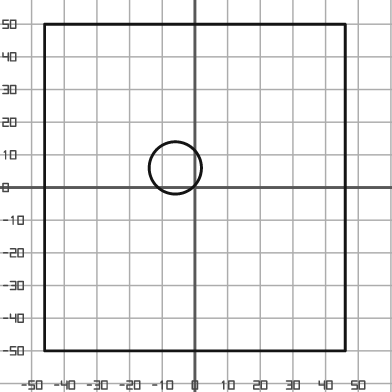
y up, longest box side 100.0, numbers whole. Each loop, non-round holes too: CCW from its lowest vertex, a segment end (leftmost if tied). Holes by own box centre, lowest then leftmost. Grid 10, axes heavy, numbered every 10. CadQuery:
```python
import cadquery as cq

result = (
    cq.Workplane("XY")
    .moveTo(-46.0, -50.0)
    .lineTo(46.0, -50.0)
    .lineTo(46.0, 50.0)
    .lineTo(-46.0, 50.0)
    .close()
    .moveTo(-6.0, 6.0)
    .circle(8.0)
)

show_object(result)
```